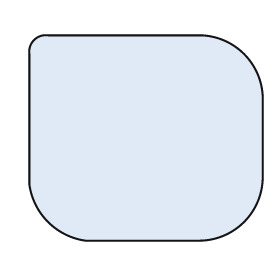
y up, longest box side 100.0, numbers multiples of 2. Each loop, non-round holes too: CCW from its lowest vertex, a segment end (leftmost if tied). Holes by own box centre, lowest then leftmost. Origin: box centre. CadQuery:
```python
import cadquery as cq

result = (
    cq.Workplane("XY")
    .moveTo(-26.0, -44.0)
    .lineTo(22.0, -44.0)
    .threePointArc((42.0, -36.0), (50.0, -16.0))
    .lineTo(50.0, 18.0)
    .threePointArc((42.0, 36.0), (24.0, 44.0))
    .lineTo(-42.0, 44.0)
    .threePointArc((-48.0, 42.0), (-50.0, 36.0))
    .lineTo(-50.0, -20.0)
    .threePointArc((-42.0, -36.0), (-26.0, -44.0))
    .close()
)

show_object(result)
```